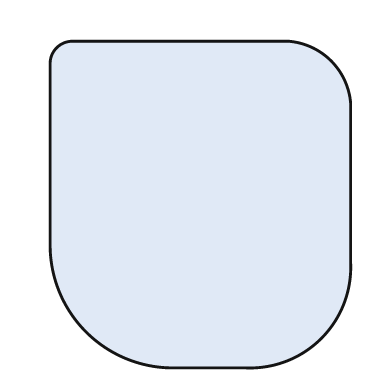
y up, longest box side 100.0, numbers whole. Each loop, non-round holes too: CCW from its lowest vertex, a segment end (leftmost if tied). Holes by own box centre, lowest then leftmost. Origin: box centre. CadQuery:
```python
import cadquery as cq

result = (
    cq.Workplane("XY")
    .moveTo(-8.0, -50.0)
    .lineTo(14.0, -50.0)
    .threePointArc((37.0, -41.0), (46.0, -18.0))
    .lineTo(46.0, 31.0)
    .threePointArc((40.0, 44.0), (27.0, 50.0))
    .lineTo(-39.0, 50.0)
    .threePointArc((-44.0, 48.0), (-46.0, 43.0))
    .lineTo(-46.0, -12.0)
    .threePointArc((-35.0, -39.0), (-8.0, -50.0))
    .close()
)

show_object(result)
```